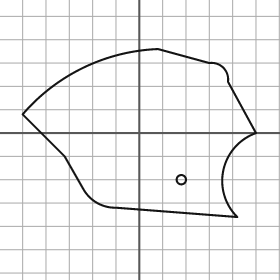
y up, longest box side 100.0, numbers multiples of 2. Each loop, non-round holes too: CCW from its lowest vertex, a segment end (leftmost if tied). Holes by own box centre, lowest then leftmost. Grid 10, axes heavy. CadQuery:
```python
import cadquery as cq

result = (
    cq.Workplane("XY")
    .moveTo(42.0, -36.0)
    .threePointArc((36.0, -16.0), (50.0, 0.0))
    .lineTo(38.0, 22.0)
    .threePointArc((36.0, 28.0), (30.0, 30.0))
    .lineTo(8.0, 36.0)
    .threePointArc((-24.0, 28.0), (-50.0, 8.0))
    .lineTo(-32.0, -10.0)
    .lineTo(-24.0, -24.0)
    .threePointArc((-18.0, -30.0), (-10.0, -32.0))
    .close()
    .moveTo(18.0, -20.0)
    .circle(2.0)
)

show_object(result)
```